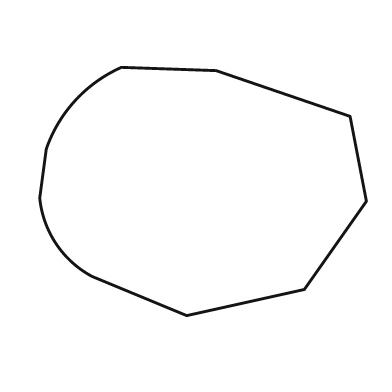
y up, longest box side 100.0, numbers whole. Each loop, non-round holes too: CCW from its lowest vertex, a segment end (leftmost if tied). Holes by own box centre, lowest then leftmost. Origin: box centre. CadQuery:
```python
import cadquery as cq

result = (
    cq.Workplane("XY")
    .moveTo(-5.0, -38.0)
    .lineTo(31.0, -30.0)
    .lineTo(50.0, -3.0)
    .lineTo(45.0, 23.0)
    .lineTo(4.0, 37.0)
    .lineTo(-25.0, 38.0)
    .threePointArc((-39.0, 28.0), (-48.0, 13.0))
    .lineTo(-50.0, -2.0)
    .threePointArc((-45.0, -16.0), (-34.0, -26.0))
    .close()
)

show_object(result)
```